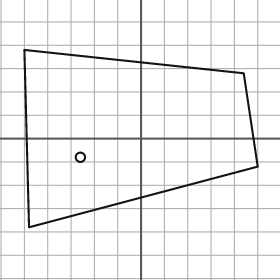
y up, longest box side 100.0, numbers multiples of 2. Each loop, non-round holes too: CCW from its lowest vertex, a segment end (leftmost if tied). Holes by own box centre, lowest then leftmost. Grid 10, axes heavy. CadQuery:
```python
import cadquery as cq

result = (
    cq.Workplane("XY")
    .moveTo(-48.0, -38.0)
    .lineTo(50.0, -12.0)
    .lineTo(44.0, 28.0)
    .lineTo(-50.0, 38.0)
    .close()
    .moveTo(-26.0, -8.0)
    .circle(2.0)
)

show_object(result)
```